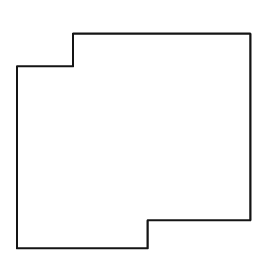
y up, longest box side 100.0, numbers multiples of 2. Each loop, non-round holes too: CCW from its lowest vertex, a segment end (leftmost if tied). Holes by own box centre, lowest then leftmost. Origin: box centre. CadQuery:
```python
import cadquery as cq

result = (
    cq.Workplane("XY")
    .moveTo(-50.0, -46.0)
    .lineTo(6.0, -46.0)
    .lineTo(6.0, -34.0)
    .lineTo(50.0, -34.0)
    .lineTo(50.0, 46.0)
    .lineTo(-26.0, 46.0)
    .lineTo(-26.0, 32.0)
    .lineTo(-50.0, 32.0)
    .close()
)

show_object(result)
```